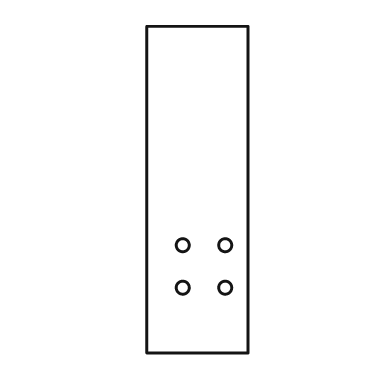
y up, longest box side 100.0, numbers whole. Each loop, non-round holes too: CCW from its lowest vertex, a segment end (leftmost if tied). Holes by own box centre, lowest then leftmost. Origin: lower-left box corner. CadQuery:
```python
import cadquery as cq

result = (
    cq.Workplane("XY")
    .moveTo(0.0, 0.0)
    .lineTo(31.0, 0.0)
    .lineTo(31.0, 100.0)
    .lineTo(0.0, 100.0)
    .close()
    .moveTo(11.0, 20.0)
    .circle(2.0)
    .moveTo(24.0, 20.0)
    .circle(2.0)
    .moveTo(11.0, 33.0)
    .circle(2.0)
    .moveTo(24.0, 33.0)
    .circle(2.0)
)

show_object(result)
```